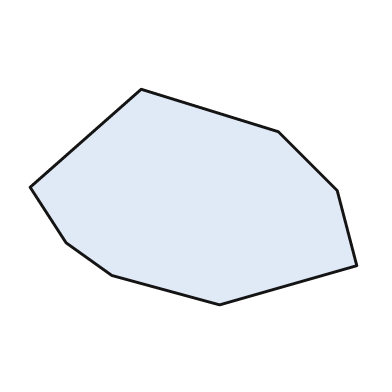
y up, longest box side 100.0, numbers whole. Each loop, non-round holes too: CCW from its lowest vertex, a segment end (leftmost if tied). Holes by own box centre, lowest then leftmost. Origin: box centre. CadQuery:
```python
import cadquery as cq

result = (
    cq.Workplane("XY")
    .moveTo(8.0, -33.0)
    .lineTo(50.0, -21.0)
    .lineTo(44.0, 2.0)
    .lineTo(26.0, 20.0)
    .lineTo(-16.0, 33.0)
    .lineTo(-50.0, 3.0)
    .lineTo(-39.0, -14.0)
    .lineTo(-25.0, -24.0)
    .close()
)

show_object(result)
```